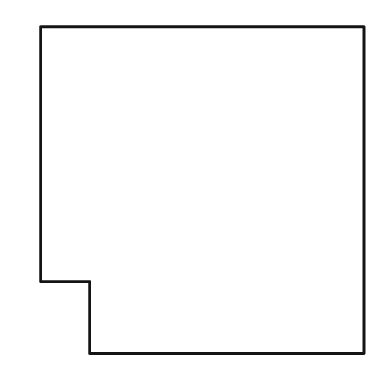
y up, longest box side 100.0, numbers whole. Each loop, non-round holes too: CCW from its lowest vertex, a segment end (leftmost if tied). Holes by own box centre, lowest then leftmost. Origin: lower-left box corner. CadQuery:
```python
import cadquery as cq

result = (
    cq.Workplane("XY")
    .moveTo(15.0, 0.0)
    .lineTo(99.0, 0.0)
    .lineTo(99.0, 100.0)
    .lineTo(0.0, 100.0)
    .lineTo(0.0, 22.0)
    .lineTo(15.0, 22.0)
    .close()
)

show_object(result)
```